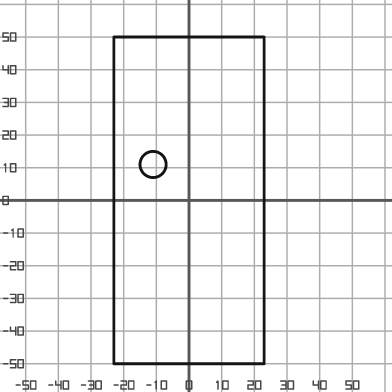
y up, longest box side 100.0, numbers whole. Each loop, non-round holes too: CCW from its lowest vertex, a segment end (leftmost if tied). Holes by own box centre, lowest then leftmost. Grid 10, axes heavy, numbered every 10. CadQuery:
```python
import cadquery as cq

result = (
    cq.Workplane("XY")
    .moveTo(-23.0, -50.0)
    .lineTo(23.0, -50.0)
    .lineTo(23.0, 50.0)
    .lineTo(-23.0, 50.0)
    .close()
    .moveTo(-11.0, 11.0)
    .circle(4.0)
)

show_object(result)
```